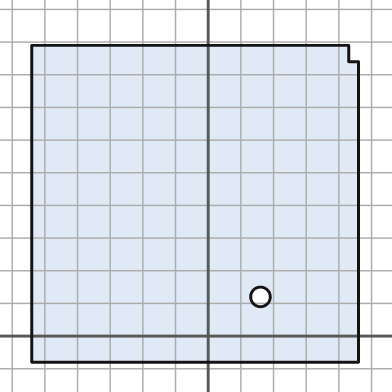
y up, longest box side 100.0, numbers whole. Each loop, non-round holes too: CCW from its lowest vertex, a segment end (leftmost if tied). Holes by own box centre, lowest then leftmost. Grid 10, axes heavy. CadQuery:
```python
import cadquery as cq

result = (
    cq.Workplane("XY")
    .moveTo(-54.0, -8.0)
    .lineTo(46.0, -8.0)
    .lineTo(46.0, 84.0)
    .lineTo(43.0, 84.0)
    .lineTo(43.0, 89.0)
    .lineTo(-54.0, 89.0)
    .close()
    .moveTo(16.0, 12.0)
    .circle(3.0)
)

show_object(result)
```